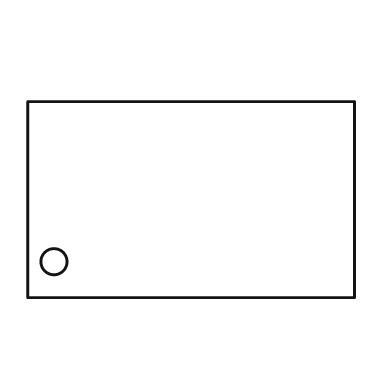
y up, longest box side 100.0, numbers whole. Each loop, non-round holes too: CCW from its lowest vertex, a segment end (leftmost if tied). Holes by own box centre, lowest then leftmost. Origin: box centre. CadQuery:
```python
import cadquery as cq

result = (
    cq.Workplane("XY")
    .moveTo(-50.0, -30.0)
    .lineTo(50.0, -30.0)
    .lineTo(50.0, 30.0)
    .lineTo(-50.0, 30.0)
    .close()
    .moveTo(-42.0, -19.0)
    .circle(4.0)
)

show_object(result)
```